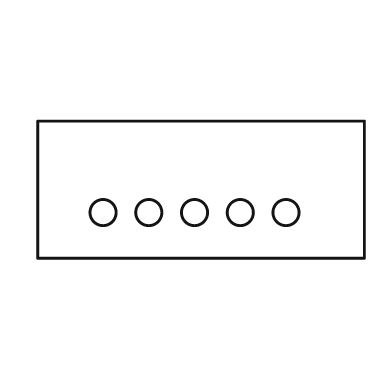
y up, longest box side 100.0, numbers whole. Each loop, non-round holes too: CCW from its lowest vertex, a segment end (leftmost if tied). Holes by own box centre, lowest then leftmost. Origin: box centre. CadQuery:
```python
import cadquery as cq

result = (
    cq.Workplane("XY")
    .moveTo(-50.0, -21.0)
    .lineTo(50.0, -21.0)
    .lineTo(50.0, 21.0)
    .lineTo(-50.0, 21.0)
    .close()
    .moveTo(-30.0, -7.0)
    .circle(4.0)
    .moveTo(-16.0, -7.0)
    .circle(4.0)
    .moveTo(-2.0, -7.0)
    .circle(4.0)
    .moveTo(12.0, -7.0)
    .circle(4.0)
    .moveTo(26.0, -7.0)
    .circle(4.0)
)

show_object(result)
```